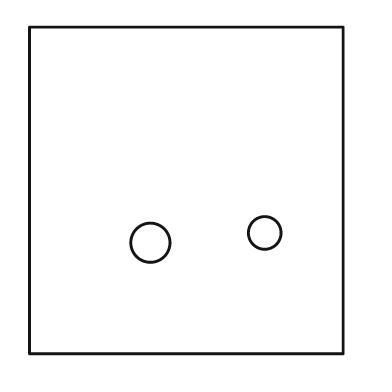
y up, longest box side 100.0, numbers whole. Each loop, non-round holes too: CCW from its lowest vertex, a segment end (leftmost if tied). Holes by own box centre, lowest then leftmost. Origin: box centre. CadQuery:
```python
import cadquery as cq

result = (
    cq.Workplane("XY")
    .moveTo(-48.0, -50.0)
    .lineTo(48.0, -50.0)
    .lineTo(48.0, 50.0)
    .lineTo(-48.0, 50.0)
    .close()
    .moveTo(-11.0, -16.0)
    .circle(6.0)
    .moveTo(24.0, -13.0)
    .circle(5.0)
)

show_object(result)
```